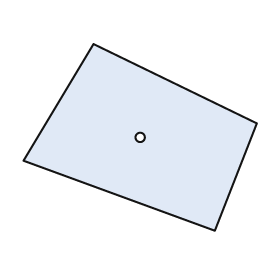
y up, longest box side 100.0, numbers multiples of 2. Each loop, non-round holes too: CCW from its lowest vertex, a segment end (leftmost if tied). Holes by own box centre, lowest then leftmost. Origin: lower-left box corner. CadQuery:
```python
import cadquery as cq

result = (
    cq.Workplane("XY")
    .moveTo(82.0, 0.0)
    .lineTo(100.0, 46.0)
    .lineTo(30.0, 80.0)
    .lineTo(0.0, 30.0)
    .close()
    .moveTo(50.0, 40.0)
    .circle(2.0)
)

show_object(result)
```